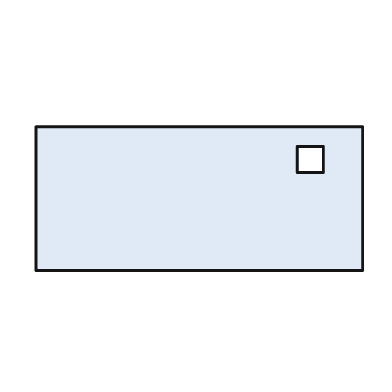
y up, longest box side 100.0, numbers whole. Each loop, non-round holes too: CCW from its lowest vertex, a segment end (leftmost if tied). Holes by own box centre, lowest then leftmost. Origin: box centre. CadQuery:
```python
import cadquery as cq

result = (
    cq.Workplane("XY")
    .moveTo(-50.0, -22.0)
    .lineTo(50.0, -22.0)
    .lineTo(50.0, 22.0)
    .lineTo(-50.0, 22.0)
    .close()
    .moveTo(30.0, 8.0)
    .lineTo(38.0, 8.0)
    .lineTo(38.0, 16.0)
    .lineTo(30.0, 16.0)
    .close()
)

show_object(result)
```